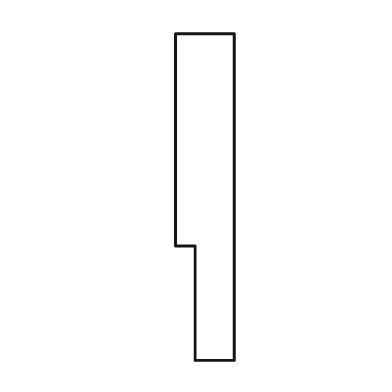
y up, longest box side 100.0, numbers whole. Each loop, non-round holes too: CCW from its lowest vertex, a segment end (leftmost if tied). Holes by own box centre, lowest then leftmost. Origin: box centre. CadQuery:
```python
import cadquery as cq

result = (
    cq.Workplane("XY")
    .moveTo(-3.0, -50.0)
    .lineTo(9.0, -50.0)
    .lineTo(9.0, 50.0)
    .lineTo(-9.0, 50.0)
    .lineTo(-9.0, -15.0)
    .lineTo(-3.0, -15.0)
    .close()
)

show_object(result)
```